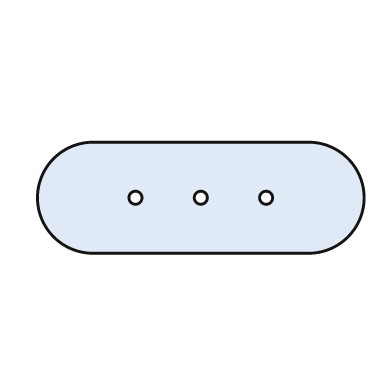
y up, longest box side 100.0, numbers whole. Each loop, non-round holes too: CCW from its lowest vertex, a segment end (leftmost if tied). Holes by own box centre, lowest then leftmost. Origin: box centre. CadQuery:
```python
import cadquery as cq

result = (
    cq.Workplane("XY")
    .moveTo(-33.0, -17.0)
    .lineTo(33.0, -17.0)
    .threePointArc((50.0, 0.0), (33.0, 17.0))
    .lineTo(-33.0, 17.0)
    .threePointArc((-50.0, 0.0), (-33.0, -17.0))
    .close()
    .moveTo(-20.0, 0.0)
    .circle(2.0)
    .moveTo(0.0, 0.0)
    .circle(2.0)
    .moveTo(20.0, 0.0)
    .circle(2.0)
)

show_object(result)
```